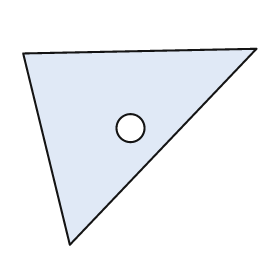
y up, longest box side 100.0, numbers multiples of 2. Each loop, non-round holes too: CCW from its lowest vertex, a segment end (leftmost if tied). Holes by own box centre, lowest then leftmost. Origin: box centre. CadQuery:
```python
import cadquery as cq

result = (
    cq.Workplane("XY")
    .moveTo(-30.0, -42.0)
    .lineTo(50.0, 42.0)
    .lineTo(-50.0, 40.0)
    .close()
    .moveTo(-4.0, 8.0)
    .circle(6.0)
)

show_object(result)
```